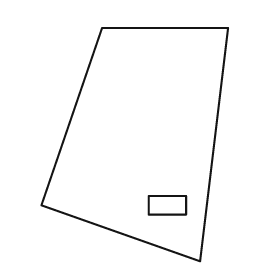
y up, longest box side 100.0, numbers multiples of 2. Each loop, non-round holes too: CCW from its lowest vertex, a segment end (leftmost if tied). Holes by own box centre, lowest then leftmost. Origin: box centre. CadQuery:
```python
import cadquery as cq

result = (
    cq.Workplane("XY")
    .moveTo(28.0, -50.0)
    .lineTo(40.0, 50.0)
    .lineTo(-14.0, 50.0)
    .lineTo(-40.0, -26.0)
    .close()
    .moveTo(6.0, -30.0)
    .lineTo(22.0, -30.0)
    .lineTo(22.0, -22.0)
    .lineTo(6.0, -22.0)
    .close()
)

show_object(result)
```